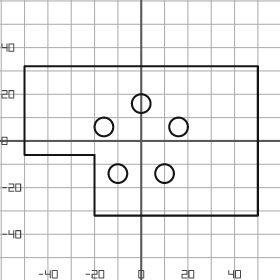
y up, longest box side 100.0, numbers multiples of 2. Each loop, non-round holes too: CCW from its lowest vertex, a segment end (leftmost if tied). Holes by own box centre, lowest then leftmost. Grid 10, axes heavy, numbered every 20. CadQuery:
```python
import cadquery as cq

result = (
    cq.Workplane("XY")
    .moveTo(-20.0, -32.0)
    .lineTo(50.0, -32.0)
    .lineTo(50.0, 32.0)
    .lineTo(-50.0, 32.0)
    .lineTo(-50.0, -6.0)
    .lineTo(-20.0, -6.0)
    .close()
    .moveTo(-10.0, -14.0)
    .circle(4.0)
    .moveTo(10.0, -14.0)
    .circle(4.0)
    .moveTo(-16.0, 6.0)
    .circle(4.0)
    .moveTo(16.0, 6.0)
    .circle(4.0)
    .moveTo(0.0, 16.0)
    .circle(4.0)
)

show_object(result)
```